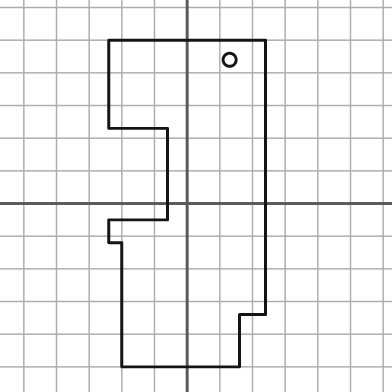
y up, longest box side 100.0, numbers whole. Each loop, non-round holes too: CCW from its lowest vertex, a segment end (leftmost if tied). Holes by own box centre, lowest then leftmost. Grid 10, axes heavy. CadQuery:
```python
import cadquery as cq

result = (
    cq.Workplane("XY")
    .moveTo(-20.0, -50.0)
    .lineTo(16.0, -50.0)
    .lineTo(16.0, -34.0)
    .lineTo(24.0, -34.0)
    .lineTo(24.0, 50.0)
    .lineTo(-24.0, 50.0)
    .lineTo(-24.0, 23.0)
    .lineTo(-6.0, 23.0)
    .lineTo(-6.0, -5.0)
    .lineTo(-24.0, -5.0)
    .lineTo(-24.0, -12.0)
    .lineTo(-20.0, -12.0)
    .close()
    .moveTo(13.0, 44.0)
    .circle(2.0)
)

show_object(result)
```